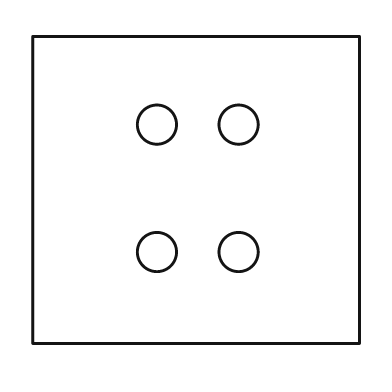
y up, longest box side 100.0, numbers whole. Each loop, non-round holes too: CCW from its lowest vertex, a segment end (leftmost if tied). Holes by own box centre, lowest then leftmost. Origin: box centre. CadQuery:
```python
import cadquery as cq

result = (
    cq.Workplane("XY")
    .moveTo(-50.0, -47.0)
    .lineTo(50.0, -47.0)
    .lineTo(50.0, 47.0)
    .lineTo(-50.0, 47.0)
    .close()
    .moveTo(-12.0, -19.0)
    .circle(6.0)
    .moveTo(13.0, -19.0)
    .circle(6.0)
    .moveTo(-12.0, 20.0)
    .circle(6.0)
    .moveTo(13.0, 20.0)
    .circle(6.0)
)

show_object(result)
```